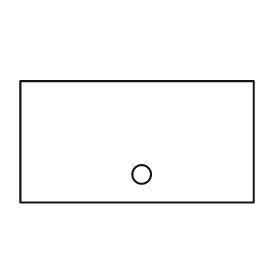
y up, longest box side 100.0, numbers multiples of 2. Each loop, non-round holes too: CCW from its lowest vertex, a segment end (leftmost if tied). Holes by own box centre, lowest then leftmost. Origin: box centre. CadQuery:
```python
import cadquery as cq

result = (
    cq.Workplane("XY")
    .moveTo(-50.0, -26.0)
    .lineTo(50.0, -26.0)
    .lineTo(50.0, 26.0)
    .lineTo(-50.0, 26.0)
    .close()
    .moveTo(2.0, -14.0)
    .circle(4.0)
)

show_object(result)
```